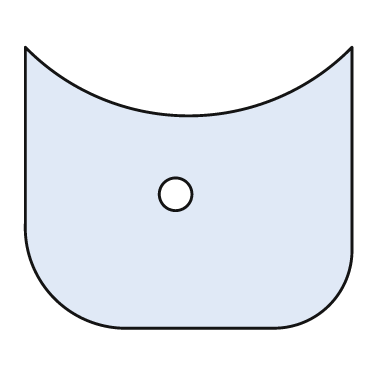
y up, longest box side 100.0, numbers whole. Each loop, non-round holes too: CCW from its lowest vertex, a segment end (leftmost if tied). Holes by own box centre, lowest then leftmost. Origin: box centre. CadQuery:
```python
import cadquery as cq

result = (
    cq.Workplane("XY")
    .moveTo(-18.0, -43.0)
    .lineTo(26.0, -43.0)
    .threePointArc((43.0, -36.0), (50.0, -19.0))
    .lineTo(50.0, 43.0)
    .threePointArc((0.0, 22.0), (-50.0, 43.0))
    .lineTo(-50.0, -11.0)
    .threePointArc((-41.0, -34.0), (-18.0, -43.0))
    .close()
    .moveTo(-4.0, -2.0)
    .circle(5.0)
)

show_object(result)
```